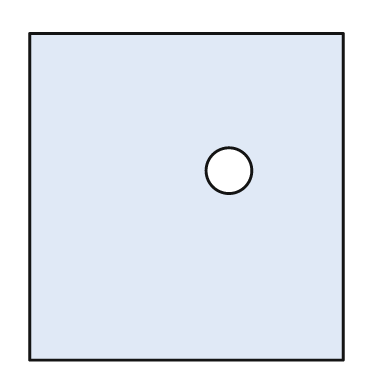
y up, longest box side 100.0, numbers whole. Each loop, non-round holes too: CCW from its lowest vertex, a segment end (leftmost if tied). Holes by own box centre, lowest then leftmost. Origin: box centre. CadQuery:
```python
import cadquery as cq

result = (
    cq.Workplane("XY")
    .moveTo(-48.0, -50.0)
    .lineTo(48.0, -50.0)
    .lineTo(48.0, 50.0)
    .lineTo(-48.0, 50.0)
    .close()
    .moveTo(13.0, 8.0)
    .circle(7.0)
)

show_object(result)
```